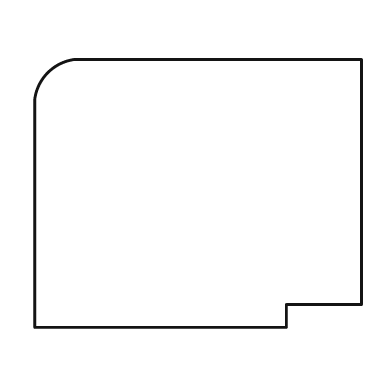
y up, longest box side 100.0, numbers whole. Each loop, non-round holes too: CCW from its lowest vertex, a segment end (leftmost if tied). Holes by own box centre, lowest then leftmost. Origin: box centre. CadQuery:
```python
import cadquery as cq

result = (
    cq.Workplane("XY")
    .moveTo(-50.0, -41.0)
    .lineTo(27.0, -41.0)
    .lineTo(27.0, -34.0)
    .lineTo(50.0, -34.0)
    .lineTo(50.0, 41.0)
    .lineTo(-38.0, 41.0)
    .threePointArc((-46.0, 37.0), (-50.0, 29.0))
    .close()
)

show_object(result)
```